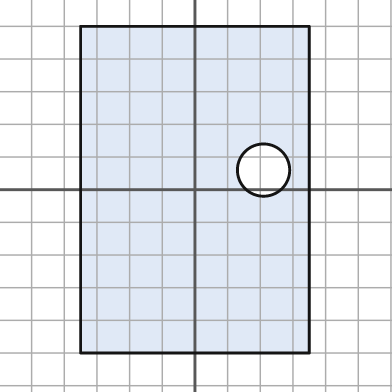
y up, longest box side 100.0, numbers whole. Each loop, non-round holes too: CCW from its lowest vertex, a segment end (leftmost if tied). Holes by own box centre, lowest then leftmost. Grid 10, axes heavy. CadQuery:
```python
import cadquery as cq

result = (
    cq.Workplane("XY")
    .moveTo(-35.0, -50.0)
    .lineTo(35.0, -50.0)
    .lineTo(35.0, 50.0)
    .lineTo(-35.0, 50.0)
    .close()
    .moveTo(21.0, 6.0)
    .circle(8.0)
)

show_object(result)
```